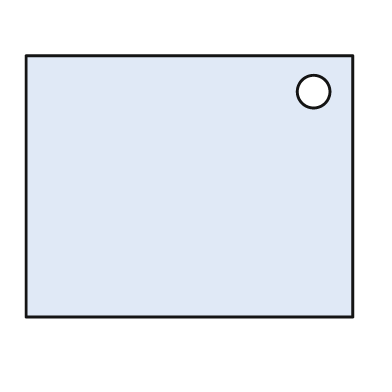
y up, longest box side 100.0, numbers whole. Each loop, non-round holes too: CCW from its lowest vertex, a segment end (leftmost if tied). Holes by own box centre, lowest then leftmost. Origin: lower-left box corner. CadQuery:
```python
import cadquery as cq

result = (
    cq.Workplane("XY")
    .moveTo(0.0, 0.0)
    .lineTo(100.0, 0.0)
    .lineTo(100.0, 80.0)
    .lineTo(0.0, 80.0)
    .close()
    .moveTo(88.0, 69.0)
    .circle(5.0)
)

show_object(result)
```